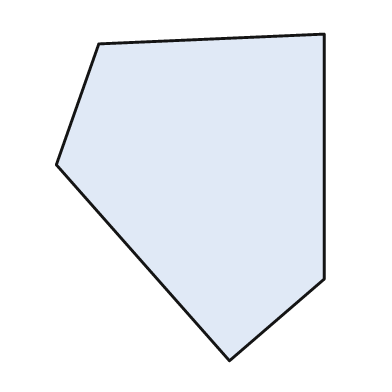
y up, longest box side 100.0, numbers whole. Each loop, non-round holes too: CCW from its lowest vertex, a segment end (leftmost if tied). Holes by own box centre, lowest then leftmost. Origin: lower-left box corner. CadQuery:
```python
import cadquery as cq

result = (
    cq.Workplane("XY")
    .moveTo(53.0, 0.0)
    .lineTo(82.0, 25.0)
    .lineTo(82.0, 100.0)
    .lineTo(13.0, 97.0)
    .lineTo(0.0, 60.0)
    .close()
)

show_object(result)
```